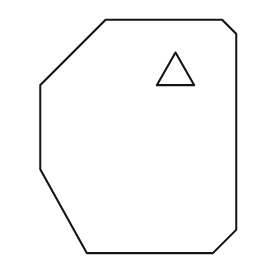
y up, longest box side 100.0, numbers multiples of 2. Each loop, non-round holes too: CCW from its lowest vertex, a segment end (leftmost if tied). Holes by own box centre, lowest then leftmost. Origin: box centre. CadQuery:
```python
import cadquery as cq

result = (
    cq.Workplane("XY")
    .moveTo(-22.0, -50.0)
    .lineTo(32.0, -50.0)
    .lineTo(42.0, -40.0)
    .lineTo(42.0, 44.0)
    .lineTo(36.0, 50.0)
    .lineTo(-14.0, 50.0)
    .lineTo(-42.0, 22.0)
    .lineTo(-42.0, -14.0)
    .close()
    .moveTo(8.0, 22.0)
    .lineTo(24.0, 22.0)
    .lineTo(16.0, 36.0)
    .close()
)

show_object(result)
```